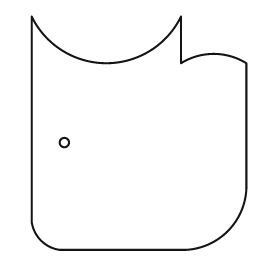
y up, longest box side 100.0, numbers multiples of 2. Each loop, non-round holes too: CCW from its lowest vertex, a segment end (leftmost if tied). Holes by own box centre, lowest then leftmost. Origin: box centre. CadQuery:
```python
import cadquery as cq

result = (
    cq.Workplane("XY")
    .moveTo(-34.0, -50.0)
    .lineTo(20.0, -50.0)
    .threePointArc((38.0, -42.0), (46.0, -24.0))
    .lineTo(46.0, 30.0)
    .threePointArc((32.0, 34.0), (18.0, 30.0))
    .lineTo(18.0, 50.0)
    .threePointArc((-14.0, 30.0), (-46.0, 50.0))
    .lineTo(-46.0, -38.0)
    .threePointArc((-42.0, -46.0), (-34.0, -50.0))
    .close()
    .moveTo(-32.0, -4.0)
    .circle(2.0)
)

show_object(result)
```